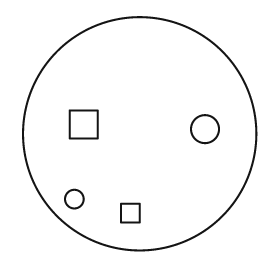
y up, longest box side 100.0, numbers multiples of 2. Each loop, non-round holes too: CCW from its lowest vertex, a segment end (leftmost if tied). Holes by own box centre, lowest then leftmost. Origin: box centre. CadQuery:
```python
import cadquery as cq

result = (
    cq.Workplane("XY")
    .moveTo(0.0, 0.0)
    .circle(50.0)
    .moveTo(-8.0, -38.0)
    .lineTo(0.0, -38.0)
    .lineTo(0.0, -30.0)
    .lineTo(-8.0, -30.0)
    .close()
    .moveTo(-28.0, -28.0)
    .circle(4.0)
    .moveTo(28.0, 2.0)
    .circle(6.0)
    .moveTo(-30.0, -2.0)
    .lineTo(-18.0, -2.0)
    .lineTo(-18.0, 10.0)
    .lineTo(-30.0, 10.0)
    .close()
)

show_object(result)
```